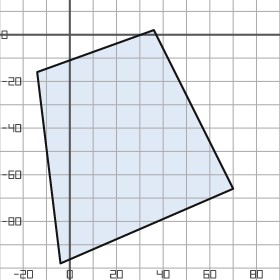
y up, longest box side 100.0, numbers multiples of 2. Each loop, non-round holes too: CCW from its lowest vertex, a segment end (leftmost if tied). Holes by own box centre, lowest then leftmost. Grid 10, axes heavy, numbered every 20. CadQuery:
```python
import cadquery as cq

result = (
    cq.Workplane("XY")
    .moveTo(-4.0, -98.0)
    .lineTo(70.0, -66.0)
    .lineTo(36.0, 2.0)
    .lineTo(-14.0, -16.0)
    .close()
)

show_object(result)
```